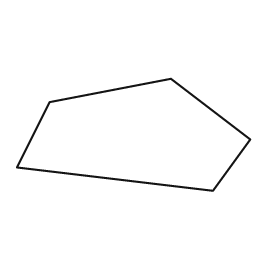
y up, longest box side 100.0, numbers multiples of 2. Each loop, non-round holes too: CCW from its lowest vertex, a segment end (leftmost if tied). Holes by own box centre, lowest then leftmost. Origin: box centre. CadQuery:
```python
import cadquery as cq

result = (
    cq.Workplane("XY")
    .moveTo(34.0, -24.0)
    .lineTo(50.0, -2.0)
    .lineTo(16.0, 24.0)
    .lineTo(-36.0, 14.0)
    .lineTo(-50.0, -14.0)
    .close()
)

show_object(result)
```